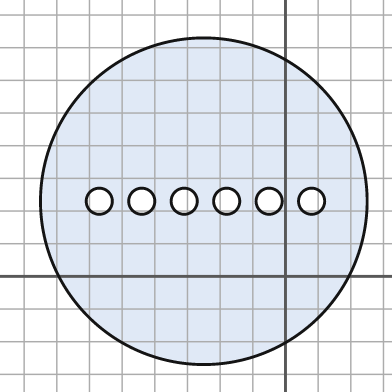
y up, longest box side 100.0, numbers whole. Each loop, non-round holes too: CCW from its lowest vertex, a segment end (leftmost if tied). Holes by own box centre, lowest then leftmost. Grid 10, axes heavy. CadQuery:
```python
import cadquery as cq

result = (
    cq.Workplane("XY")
    .moveTo(-25.0, 23.0)
    .circle(50.0)
    .moveTo(-57.0, 23.0)
    .circle(4.0)
    .moveTo(-44.0, 23.0)
    .circle(4.0)
    .moveTo(-31.0, 23.0)
    .circle(4.0)
    .moveTo(-18.0, 23.0)
    .circle(4.0)
    .moveTo(-5.0, 23.0)
    .circle(4.0)
    .moveTo(8.0, 23.0)
    .circle(4.0)
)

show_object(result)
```